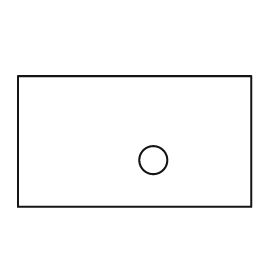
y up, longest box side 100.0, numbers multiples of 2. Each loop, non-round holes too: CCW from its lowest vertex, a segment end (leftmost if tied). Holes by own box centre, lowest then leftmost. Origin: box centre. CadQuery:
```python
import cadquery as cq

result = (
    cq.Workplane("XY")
    .moveTo(-50.0, -28.0)
    .lineTo(50.0, -28.0)
    .lineTo(50.0, 28.0)
    .lineTo(-50.0, 28.0)
    .close()
    .moveTo(8.0, -8.0)
    .circle(6.0)
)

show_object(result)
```